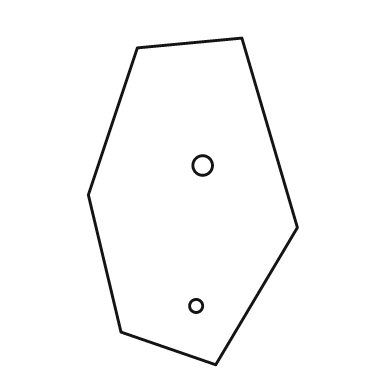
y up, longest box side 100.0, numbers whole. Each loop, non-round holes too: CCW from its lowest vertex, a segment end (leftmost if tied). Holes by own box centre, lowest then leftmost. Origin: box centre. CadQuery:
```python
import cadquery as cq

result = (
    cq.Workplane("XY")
    .moveTo(7.0, -50.0)
    .lineTo(32.0, -8.0)
    .lineTo(15.0, 50.0)
    .lineTo(-17.0, 47.0)
    .lineTo(-32.0, 2.0)
    .lineTo(-22.0, -40.0)
    .close()
    .moveTo(1.0, -32.0)
    .circle(2.0)
    .moveTo(3.0, 11.0)
    .circle(3.0)
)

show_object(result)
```